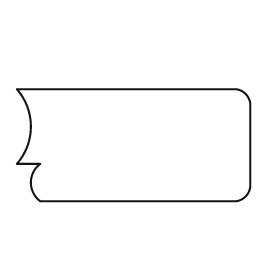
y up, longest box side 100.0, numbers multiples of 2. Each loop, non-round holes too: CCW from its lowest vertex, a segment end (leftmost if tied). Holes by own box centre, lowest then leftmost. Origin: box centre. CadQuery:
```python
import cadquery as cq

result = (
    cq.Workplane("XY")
    .moveTo(-40.0, -24.0)
    .lineTo(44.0, -24.0)
    .threePointArc((48.0, -22.0), (50.0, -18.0))
    .lineTo(50.0, 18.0)
    .threePointArc((48.0, 22.0), (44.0, 24.0))
    .lineTo(-50.0, 24.0)
    .threePointArc((-44.0, 8.0), (-50.0, -8.0))
    .lineTo(-40.0, -8.0)
    .threePointArc((-44.0, -16.0), (-40.0, -24.0))
    .close()
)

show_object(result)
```